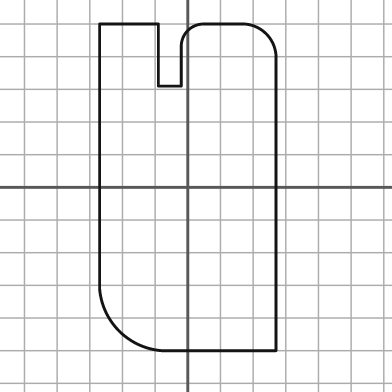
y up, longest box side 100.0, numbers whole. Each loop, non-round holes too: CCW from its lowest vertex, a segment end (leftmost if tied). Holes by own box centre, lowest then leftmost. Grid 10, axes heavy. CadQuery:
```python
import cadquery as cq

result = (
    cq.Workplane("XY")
    .moveTo(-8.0, -50.0)
    .lineTo(27.0, -50.0)
    .lineTo(27.0, 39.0)
    .threePointArc((24.0, 47.0), (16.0, 50.0))
    .lineTo(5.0, 50.0)
    .threePointArc((0.0, 48.0), (-2.0, 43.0))
    .lineTo(-2.0, 31.0)
    .lineTo(-9.0, 31.0)
    .lineTo(-9.0, 50.0)
    .lineTo(-27.0, 50.0)
    .lineTo(-27.0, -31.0)
    .threePointArc((-21.0, -44.0), (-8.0, -50.0))
    .close()
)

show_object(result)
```